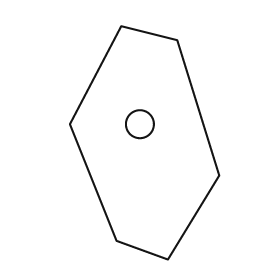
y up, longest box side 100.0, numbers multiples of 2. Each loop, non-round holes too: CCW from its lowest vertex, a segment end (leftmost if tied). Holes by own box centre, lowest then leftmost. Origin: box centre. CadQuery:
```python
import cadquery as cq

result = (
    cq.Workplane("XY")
    .moveTo(10.0, -50.0)
    .lineTo(32.0, -14.0)
    .lineTo(14.0, 44.0)
    .lineTo(-10.0, 50.0)
    .lineTo(-32.0, 8.0)
    .lineTo(-12.0, -42.0)
    .close()
    .moveTo(-2.0, 8.0)
    .circle(6.0)
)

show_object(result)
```